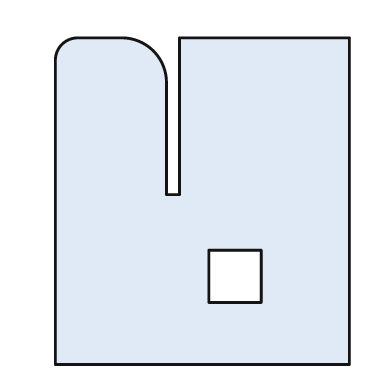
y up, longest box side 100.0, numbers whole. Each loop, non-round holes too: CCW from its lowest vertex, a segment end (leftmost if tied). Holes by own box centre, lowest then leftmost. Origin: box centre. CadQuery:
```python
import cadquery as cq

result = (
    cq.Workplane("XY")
    .moveTo(-45.0, -50.0)
    .lineTo(45.0, -50.0)
    .lineTo(45.0, 50.0)
    .lineTo(-7.0, 50.0)
    .lineTo(-7.0, 2.0)
    .lineTo(-11.0, 2.0)
    .lineTo(-11.0, 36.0)
    .threePointArc((-15.0, 46.0), (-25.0, 50.0))
    .lineTo(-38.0, 50.0)
    .threePointArc((-43.0, 48.0), (-45.0, 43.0))
    .close()
    .moveTo(2.0, -31.0)
    .lineTo(18.0, -31.0)
    .lineTo(18.0, -15.0)
    .lineTo(2.0, -15.0)
    .close()
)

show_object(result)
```